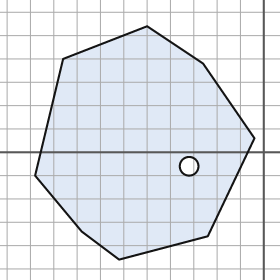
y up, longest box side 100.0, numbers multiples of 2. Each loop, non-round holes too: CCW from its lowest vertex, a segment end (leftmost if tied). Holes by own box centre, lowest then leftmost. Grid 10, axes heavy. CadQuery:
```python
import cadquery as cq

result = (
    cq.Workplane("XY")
    .moveTo(-62.0, -46.0)
    .lineTo(-24.0, -36.0)
    .lineTo(-4.0, 6.0)
    .lineTo(-26.0, 38.0)
    .lineTo(-50.0, 54.0)
    .lineTo(-86.0, 40.0)
    .lineTo(-98.0, -10.0)
    .lineTo(-78.0, -34.0)
    .close()
    .moveTo(-32.0, -6.0)
    .circle(4.0)
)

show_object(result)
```